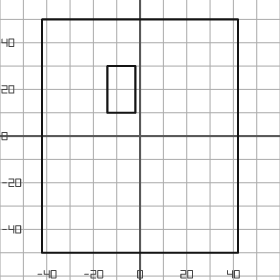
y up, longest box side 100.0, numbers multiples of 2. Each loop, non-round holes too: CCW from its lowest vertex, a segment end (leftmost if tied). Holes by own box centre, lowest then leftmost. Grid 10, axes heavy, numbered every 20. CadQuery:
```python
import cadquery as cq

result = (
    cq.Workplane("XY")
    .moveTo(-42.0, -50.0)
    .lineTo(42.0, -50.0)
    .lineTo(42.0, 50.0)
    .lineTo(-42.0, 50.0)
    .close()
    .moveTo(-14.0, 10.0)
    .lineTo(-2.0, 10.0)
    .lineTo(-2.0, 30.0)
    .lineTo(-14.0, 30.0)
    .close()
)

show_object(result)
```